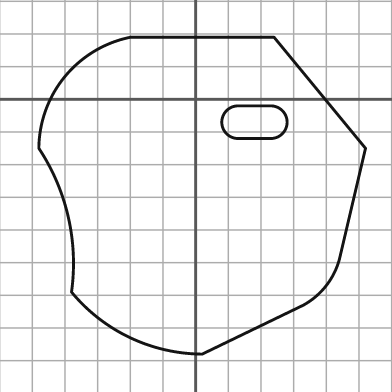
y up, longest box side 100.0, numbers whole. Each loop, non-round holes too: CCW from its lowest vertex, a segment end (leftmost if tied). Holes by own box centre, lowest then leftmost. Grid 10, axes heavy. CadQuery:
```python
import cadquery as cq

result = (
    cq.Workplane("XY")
    .moveTo(2.0, -78.0)
    .lineTo(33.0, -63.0)
    .threePointArc((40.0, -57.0), (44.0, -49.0))
    .lineTo(52.0, -15.0)
    .lineTo(24.0, 19.0)
    .lineTo(-20.0, 19.0)
    .threePointArc((-40.0, 7.0), (-48.0, -15.0))
    .threePointArc((-39.0, -36.0), (-38.0, -59.0))
    .threePointArc((-20.0, -73.0), (2.0, -78.0))
    .close()
    .moveTo(13.0, -12.0)
    .lineTo(23.0, -12.0)
    .threePointArc((28.0, -7.0), (23.0, -2.0))
    .lineTo(13.0, -2.0)
    .threePointArc((8.0, -7.0), (13.0, -12.0))
    .close()
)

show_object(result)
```